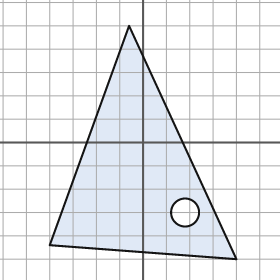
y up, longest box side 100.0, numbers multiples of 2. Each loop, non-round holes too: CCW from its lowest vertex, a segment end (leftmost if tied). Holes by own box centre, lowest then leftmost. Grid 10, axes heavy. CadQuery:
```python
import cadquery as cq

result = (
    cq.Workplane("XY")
    .moveTo(40.0, -50.0)
    .lineTo(-6.0, 50.0)
    .lineTo(-40.0, -44.0)
    .close()
    .moveTo(18.0, -30.0)
    .circle(6.0)
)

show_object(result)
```